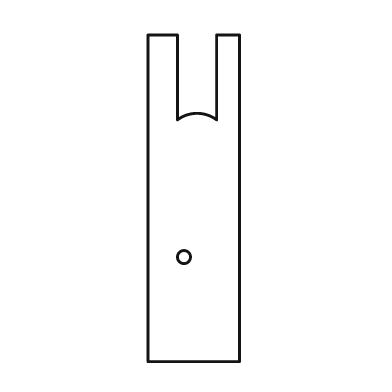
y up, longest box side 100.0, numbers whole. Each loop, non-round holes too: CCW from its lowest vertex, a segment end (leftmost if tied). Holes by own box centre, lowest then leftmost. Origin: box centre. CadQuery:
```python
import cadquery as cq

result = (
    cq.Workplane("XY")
    .moveTo(-14.0, -50.0)
    .lineTo(14.0, -50.0)
    .lineTo(14.0, 50.0)
    .lineTo(7.0, 50.0)
    .lineTo(7.0, 24.0)
    .threePointArc((1.0, 26.0), (-5.0, 24.0))
    .lineTo(-5.0, 50.0)
    .lineTo(-14.0, 50.0)
    .close()
    .moveTo(-3.0, -18.0)
    .circle(2.0)
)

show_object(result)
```